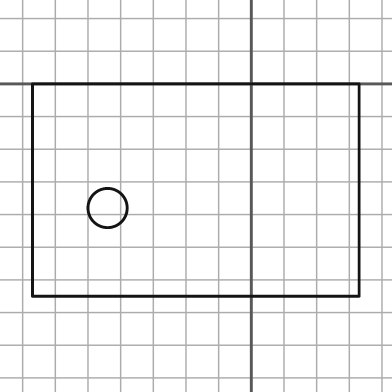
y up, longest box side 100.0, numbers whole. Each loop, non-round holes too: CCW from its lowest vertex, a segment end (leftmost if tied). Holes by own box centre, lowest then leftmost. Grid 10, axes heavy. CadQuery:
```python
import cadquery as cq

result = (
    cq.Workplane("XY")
    .moveTo(-67.0, -65.0)
    .lineTo(33.0, -65.0)
    .lineTo(33.0, 0.0)
    .lineTo(-67.0, 0.0)
    .close()
    .moveTo(-44.0, -38.0)
    .circle(6.0)
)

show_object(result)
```